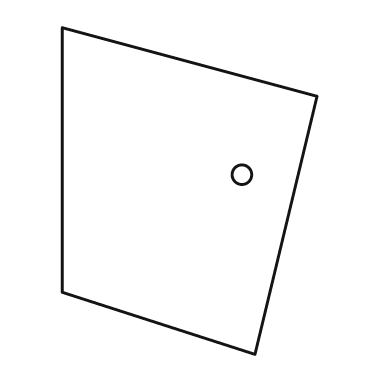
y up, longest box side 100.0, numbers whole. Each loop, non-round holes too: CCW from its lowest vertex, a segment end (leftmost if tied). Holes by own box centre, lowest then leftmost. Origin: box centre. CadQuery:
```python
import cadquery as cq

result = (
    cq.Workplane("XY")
    .moveTo(20.0, -50.0)
    .lineTo(39.0, 29.0)
    .lineTo(-39.0, 50.0)
    .lineTo(-39.0, -31.0)
    .close()
    .moveTo(16.0, 5.0)
    .circle(3.0)
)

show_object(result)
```